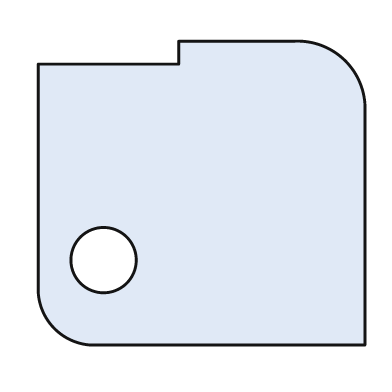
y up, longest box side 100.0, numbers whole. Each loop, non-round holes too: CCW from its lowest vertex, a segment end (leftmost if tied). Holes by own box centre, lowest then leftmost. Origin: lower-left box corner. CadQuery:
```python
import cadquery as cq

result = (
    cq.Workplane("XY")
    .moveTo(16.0, 0.0)
    .lineTo(100.0, 0.0)
    .lineTo(100.0, 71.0)
    .threePointArc((94.0, 87.0), (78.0, 93.0))
    .lineTo(43.0, 93.0)
    .lineTo(43.0, 86.0)
    .lineTo(0.0, 86.0)
    .lineTo(0.0, 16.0)
    .threePointArc((5.0, 5.0), (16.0, 0.0))
    .close()
    .moveTo(20.0, 26.0)
    .circle(10.0)
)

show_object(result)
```